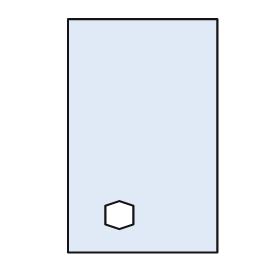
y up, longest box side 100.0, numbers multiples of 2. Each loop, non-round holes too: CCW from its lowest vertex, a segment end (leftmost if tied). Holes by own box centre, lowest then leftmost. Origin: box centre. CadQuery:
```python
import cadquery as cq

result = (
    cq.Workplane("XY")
    .moveTo(-32.0, -50.0)
    .lineTo(32.0, -50.0)
    .lineTo(32.0, 50.0)
    .lineTo(-32.0, 50.0)
    .close()
    .moveTo(-10.0, -40.0)
    .lineTo(-4.0, -38.0)
    .lineTo(-4.0, -30.0)
    .lineTo(-10.0, -28.0)
    .lineTo(-16.0, -30.0)
    .lineTo(-16.0, -38.0)
    .close()
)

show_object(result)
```